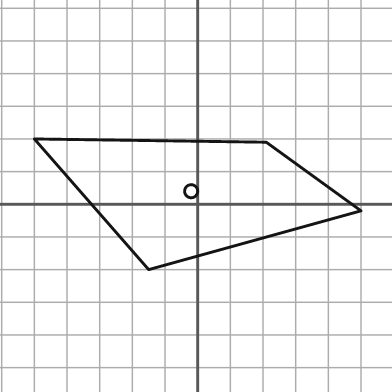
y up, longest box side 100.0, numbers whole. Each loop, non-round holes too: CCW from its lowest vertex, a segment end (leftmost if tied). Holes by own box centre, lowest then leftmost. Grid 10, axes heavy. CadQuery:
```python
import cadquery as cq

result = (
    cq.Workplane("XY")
    .moveTo(-15.0, -20.0)
    .lineTo(50.0, -2.0)
    .lineTo(21.0, 19.0)
    .lineTo(-50.0, 20.0)
    .close()
    .moveTo(-2.0, 4.0)
    .circle(2.0)
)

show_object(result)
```